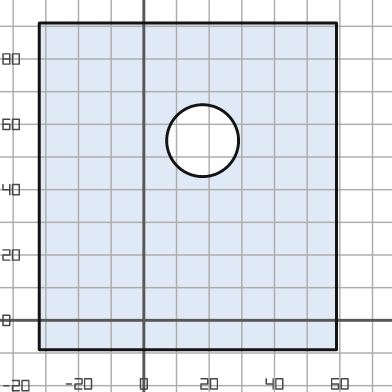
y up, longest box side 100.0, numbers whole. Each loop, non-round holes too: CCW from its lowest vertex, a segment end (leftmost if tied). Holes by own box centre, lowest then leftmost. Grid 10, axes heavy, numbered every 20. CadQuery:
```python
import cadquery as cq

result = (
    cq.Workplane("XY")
    .moveTo(-32.0, -9.0)
    .lineTo(59.0, -9.0)
    .lineTo(59.0, 91.0)
    .lineTo(-32.0, 91.0)
    .close()
    .moveTo(18.0, 55.0)
    .circle(11.0)
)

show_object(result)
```